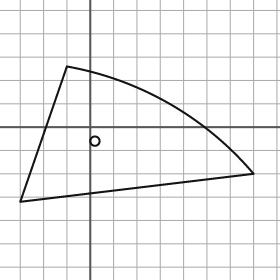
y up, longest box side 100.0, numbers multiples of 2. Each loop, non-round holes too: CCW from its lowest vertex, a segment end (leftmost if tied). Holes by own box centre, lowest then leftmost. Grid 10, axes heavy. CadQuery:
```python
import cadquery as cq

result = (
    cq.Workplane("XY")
    .moveTo(-30.0, -32.0)
    .lineTo(70.0, -20.0)
    .threePointArc((34.0, 10.0), (-10.0, 26.0))
    .close()
    .moveTo(2.0, -6.0)
    .circle(2.0)
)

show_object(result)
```